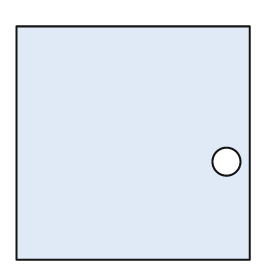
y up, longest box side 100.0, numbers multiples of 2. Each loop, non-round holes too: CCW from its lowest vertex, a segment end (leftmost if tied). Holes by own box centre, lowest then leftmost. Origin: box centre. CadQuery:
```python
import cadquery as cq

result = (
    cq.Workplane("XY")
    .moveTo(-50.0, -50.0)
    .lineTo(50.0, -50.0)
    .lineTo(50.0, 50.0)
    .lineTo(-50.0, 50.0)
    .close()
    .moveTo(40.0, -8.0)
    .circle(6.0)
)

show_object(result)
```